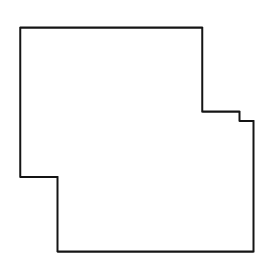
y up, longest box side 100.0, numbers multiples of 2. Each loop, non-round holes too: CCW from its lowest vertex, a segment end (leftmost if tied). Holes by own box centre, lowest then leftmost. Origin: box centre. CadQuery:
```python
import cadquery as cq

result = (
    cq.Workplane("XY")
    .moveTo(-34.0, -48.0)
    .lineTo(50.0, -48.0)
    .lineTo(50.0, 8.0)
    .lineTo(44.0, 8.0)
    .lineTo(44.0, 12.0)
    .lineTo(28.0, 12.0)
    .lineTo(28.0, 48.0)
    .lineTo(-50.0, 48.0)
    .lineTo(-50.0, -16.0)
    .lineTo(-34.0, -16.0)
    .close()
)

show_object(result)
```